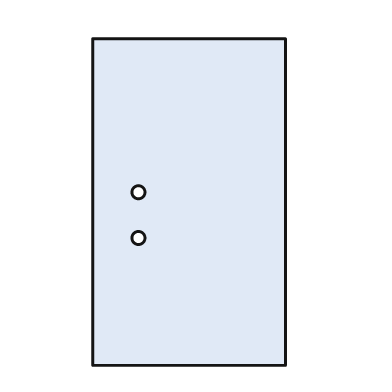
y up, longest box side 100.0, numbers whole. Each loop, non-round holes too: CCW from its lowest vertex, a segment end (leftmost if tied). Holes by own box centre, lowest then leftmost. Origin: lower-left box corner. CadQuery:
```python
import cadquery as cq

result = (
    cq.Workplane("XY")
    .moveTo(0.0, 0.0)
    .lineTo(59.0, 0.0)
    .lineTo(59.0, 100.0)
    .lineTo(0.0, 100.0)
    .close()
    .moveTo(14.0, 39.0)
    .circle(2.0)
    .moveTo(14.0, 53.0)
    .circle(2.0)
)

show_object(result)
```